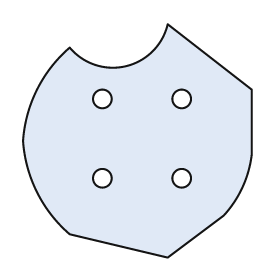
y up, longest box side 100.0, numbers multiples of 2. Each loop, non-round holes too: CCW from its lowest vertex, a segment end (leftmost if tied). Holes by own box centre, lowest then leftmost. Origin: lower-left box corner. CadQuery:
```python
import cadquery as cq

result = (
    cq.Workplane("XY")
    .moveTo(62.0, 0.0)
    .lineTo(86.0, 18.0)
    .threePointArc((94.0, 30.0), (98.0, 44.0))
    .lineTo(98.0, 72.0)
    .lineTo(62.0, 100.0)
    .threePointArc((44.0, 82.0), (20.0, 90.0))
    .threePointArc((6.0, 72.0), (0.0, 50.0))
    .threePointArc((6.0, 28.0), (20.0, 10.0))
    .close()
    .moveTo(34.0, 34.0)
    .circle(4.0)
    .moveTo(68.0, 34.0)
    .circle(4.0)
    .moveTo(34.0, 68.0)
    .circle(4.0)
    .moveTo(68.0, 68.0)
    .circle(4.0)
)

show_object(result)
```